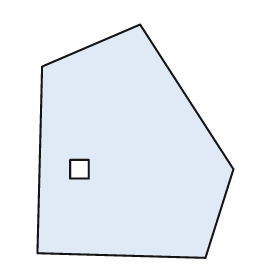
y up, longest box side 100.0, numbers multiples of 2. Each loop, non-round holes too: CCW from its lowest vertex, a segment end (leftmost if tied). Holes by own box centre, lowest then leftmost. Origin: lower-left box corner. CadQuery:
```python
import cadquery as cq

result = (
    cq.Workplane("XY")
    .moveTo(72.0, 0.0)
    .lineTo(84.0, 38.0)
    .lineTo(44.0, 100.0)
    .lineTo(2.0, 82.0)
    .lineTo(0.0, 2.0)
    .close()
    .moveTo(14.0, 34.0)
    .lineTo(22.0, 34.0)
    .lineTo(22.0, 42.0)
    .lineTo(14.0, 42.0)
    .close()
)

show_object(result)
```